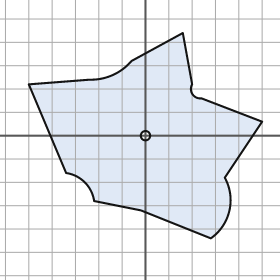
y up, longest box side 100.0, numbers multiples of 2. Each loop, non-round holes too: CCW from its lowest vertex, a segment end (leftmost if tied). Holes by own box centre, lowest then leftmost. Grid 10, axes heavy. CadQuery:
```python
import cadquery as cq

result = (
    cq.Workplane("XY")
    .moveTo(28.0, -44.0)
    .threePointArc((36.0, -32.0), (34.0, -18.0))
    .lineTo(50.0, 6.0)
    .lineTo(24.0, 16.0)
    .threePointArc((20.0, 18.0), (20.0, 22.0))
    .lineTo(16.0, 44.0)
    .lineTo(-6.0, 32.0)
    .threePointArc((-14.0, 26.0), (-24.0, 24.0))
    .lineTo(-50.0, 22.0)
    .lineTo(-34.0, -16.0)
    .threePointArc((-26.0, -20.0), (-22.0, -28.0))
    .lineTo(-2.0, -32.0)
    .close()
    .moveTo(0.0, 0.0)
    .circle(2.0)
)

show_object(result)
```